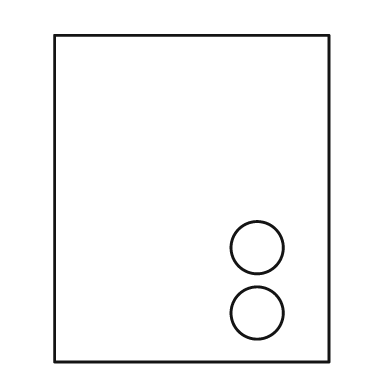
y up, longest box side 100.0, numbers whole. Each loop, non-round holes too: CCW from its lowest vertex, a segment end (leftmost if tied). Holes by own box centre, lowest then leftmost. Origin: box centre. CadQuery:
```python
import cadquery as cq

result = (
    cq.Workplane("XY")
    .moveTo(-42.0, -50.0)
    .lineTo(42.0, -50.0)
    .lineTo(42.0, 50.0)
    .lineTo(-42.0, 50.0)
    .close()
    .moveTo(20.0, -35.0)
    .circle(8.0)
    .moveTo(20.0, -15.0)
    .circle(8.0)
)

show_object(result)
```